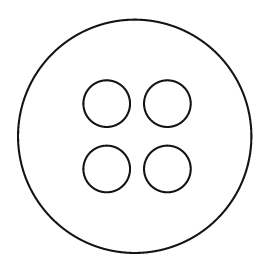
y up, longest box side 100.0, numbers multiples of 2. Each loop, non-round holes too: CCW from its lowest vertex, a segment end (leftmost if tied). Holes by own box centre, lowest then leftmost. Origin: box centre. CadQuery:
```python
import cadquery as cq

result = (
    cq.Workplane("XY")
    .moveTo(0.0, 0.0)
    .circle(50.0)
    .moveTo(-12.0, -14.0)
    .circle(10.0)
    .moveTo(14.0, -14.0)
    .circle(10.0)
    .moveTo(-12.0, 14.0)
    .circle(10.0)
    .moveTo(14.0, 14.0)
    .circle(10.0)
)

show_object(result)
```